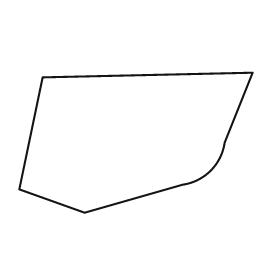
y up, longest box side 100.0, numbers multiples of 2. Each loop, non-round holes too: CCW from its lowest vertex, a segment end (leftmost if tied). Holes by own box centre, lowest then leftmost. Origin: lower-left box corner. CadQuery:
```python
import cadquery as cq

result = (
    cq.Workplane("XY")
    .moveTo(28.0, 0.0)
    .lineTo(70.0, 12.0)
    .threePointArc((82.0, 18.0), (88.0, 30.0))
    .lineTo(100.0, 60.0)
    .lineTo(10.0, 58.0)
    .lineTo(0.0, 10.0)
    .close()
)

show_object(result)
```